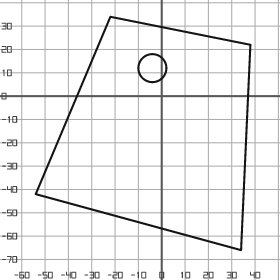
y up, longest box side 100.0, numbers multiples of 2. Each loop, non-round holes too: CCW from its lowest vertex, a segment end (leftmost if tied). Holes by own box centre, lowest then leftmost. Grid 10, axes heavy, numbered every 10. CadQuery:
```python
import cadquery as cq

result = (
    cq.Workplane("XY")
    .moveTo(34.0, -66.0)
    .lineTo(38.0, 22.0)
    .lineTo(-22.0, 34.0)
    .lineTo(-54.0, -42.0)
    .close()
    .moveTo(-4.0, 12.0)
    .circle(6.0)
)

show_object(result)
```